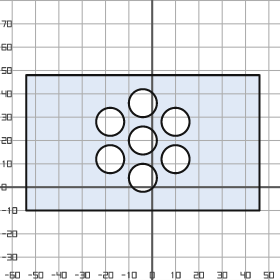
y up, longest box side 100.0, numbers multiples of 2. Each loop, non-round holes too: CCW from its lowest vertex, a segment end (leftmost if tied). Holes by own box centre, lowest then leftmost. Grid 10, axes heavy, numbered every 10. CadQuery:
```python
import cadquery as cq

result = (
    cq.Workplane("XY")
    .moveTo(-54.0, -10.0)
    .lineTo(46.0, -10.0)
    .lineTo(46.0, 48.0)
    .lineTo(-54.0, 48.0)
    .close()
    .moveTo(-4.0, 4.0)
    .circle(6.0)
    .moveTo(-18.0, 12.0)
    .circle(6.0)
    .moveTo(10.0, 12.0)
    .circle(6.0)
    .moveTo(-4.0, 20.0)
    .circle(6.0)
    .moveTo(-18.0, 28.0)
    .circle(6.0)
    .moveTo(10.0, 28.0)
    .circle(6.0)
    .moveTo(-4.0, 36.0)
    .circle(6.0)
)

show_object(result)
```